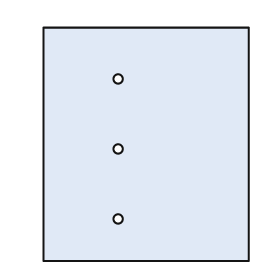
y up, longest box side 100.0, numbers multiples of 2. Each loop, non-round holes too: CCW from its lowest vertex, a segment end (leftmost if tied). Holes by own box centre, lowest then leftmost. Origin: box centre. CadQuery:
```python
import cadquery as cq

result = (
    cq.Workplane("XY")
    .moveTo(-44.0, -50.0)
    .lineTo(44.0, -50.0)
    .lineTo(44.0, 50.0)
    .lineTo(-44.0, 50.0)
    .close()
    .moveTo(-12.0, -32.0)
    .circle(2.0)
    .moveTo(-12.0, -2.0)
    .circle(2.0)
    .moveTo(-12.0, 28.0)
    .circle(2.0)
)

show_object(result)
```